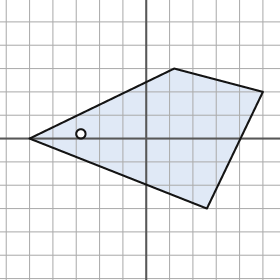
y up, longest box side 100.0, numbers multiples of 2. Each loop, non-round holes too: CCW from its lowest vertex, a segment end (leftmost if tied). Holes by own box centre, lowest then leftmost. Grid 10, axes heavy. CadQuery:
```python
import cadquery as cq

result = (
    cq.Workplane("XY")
    .moveTo(26.0, -30.0)
    .lineTo(50.0, 20.0)
    .lineTo(12.0, 30.0)
    .lineTo(-50.0, 0.0)
    .close()
    .moveTo(-28.0, 2.0)
    .circle(2.0)
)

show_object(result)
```